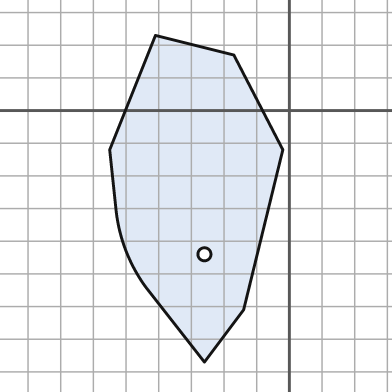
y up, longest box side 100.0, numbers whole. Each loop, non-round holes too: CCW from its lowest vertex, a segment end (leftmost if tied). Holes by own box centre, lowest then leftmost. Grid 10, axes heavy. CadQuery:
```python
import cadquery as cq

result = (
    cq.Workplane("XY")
    .moveTo(-26.0, -77.0)
    .lineTo(-14.0, -61.0)
    .lineTo(-2.0, -12.0)
    .lineTo(-17.0, 17.0)
    .lineTo(-41.0, 23.0)
    .lineTo(-55.0, -12.0)
    .lineTo(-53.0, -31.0)
    .threePointArc((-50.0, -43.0), (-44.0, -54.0))
    .close()
    .moveTo(-26.0, -44.0)
    .circle(2.0)
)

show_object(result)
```